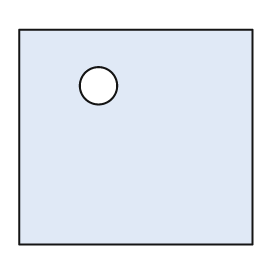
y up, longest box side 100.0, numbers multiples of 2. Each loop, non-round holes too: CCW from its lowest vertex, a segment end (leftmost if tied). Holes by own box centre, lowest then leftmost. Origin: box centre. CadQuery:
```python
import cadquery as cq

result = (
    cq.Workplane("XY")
    .moveTo(-50.0, -46.0)
    .lineTo(50.0, -46.0)
    .lineTo(50.0, 46.0)
    .lineTo(-50.0, 46.0)
    .close()
    .moveTo(-16.0, 22.0)
    .circle(8.0)
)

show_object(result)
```